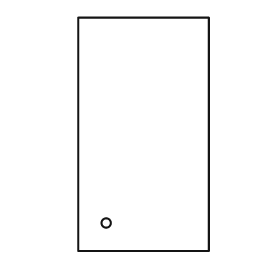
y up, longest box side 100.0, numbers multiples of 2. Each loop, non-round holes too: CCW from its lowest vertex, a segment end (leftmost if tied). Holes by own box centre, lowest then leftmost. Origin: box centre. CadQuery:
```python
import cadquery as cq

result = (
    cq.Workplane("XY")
    .moveTo(-28.0, -50.0)
    .lineTo(28.0, -50.0)
    .lineTo(28.0, 50.0)
    .lineTo(-28.0, 50.0)
    .close()
    .moveTo(-16.0, -38.0)
    .circle(2.0)
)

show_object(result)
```